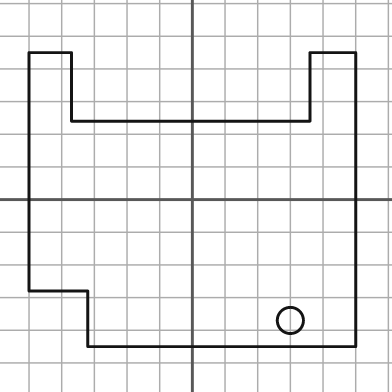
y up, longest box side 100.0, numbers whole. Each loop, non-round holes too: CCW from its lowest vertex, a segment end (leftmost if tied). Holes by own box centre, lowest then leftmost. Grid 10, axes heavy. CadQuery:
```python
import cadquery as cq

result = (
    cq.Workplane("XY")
    .moveTo(-32.0, -45.0)
    .lineTo(50.0, -45.0)
    .lineTo(50.0, 45.0)
    .lineTo(36.0, 45.0)
    .lineTo(36.0, 24.0)
    .lineTo(-37.0, 24.0)
    .lineTo(-37.0, 45.0)
    .lineTo(-50.0, 45.0)
    .lineTo(-50.0, -28.0)
    .lineTo(-32.0, -28.0)
    .close()
    .moveTo(30.0, -37.0)
    .circle(4.0)
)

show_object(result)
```